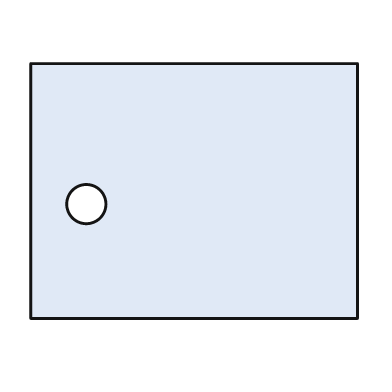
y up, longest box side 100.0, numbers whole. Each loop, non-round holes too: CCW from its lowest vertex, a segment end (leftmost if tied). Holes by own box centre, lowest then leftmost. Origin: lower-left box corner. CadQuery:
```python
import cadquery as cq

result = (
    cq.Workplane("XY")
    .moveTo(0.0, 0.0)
    .lineTo(100.0, 0.0)
    .lineTo(100.0, 78.0)
    .lineTo(0.0, 78.0)
    .close()
    .moveTo(17.0, 35.0)
    .circle(6.0)
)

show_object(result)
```